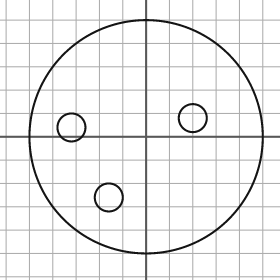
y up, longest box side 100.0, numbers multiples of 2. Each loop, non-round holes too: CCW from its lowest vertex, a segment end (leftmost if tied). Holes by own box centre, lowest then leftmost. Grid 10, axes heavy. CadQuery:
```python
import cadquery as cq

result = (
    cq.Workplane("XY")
    .moveTo(0.0, 0.0)
    .circle(50.0)
    .moveTo(-16.0, -26.0)
    .circle(6.0)
    .moveTo(-32.0, 4.0)
    .circle(6.0)
    .moveTo(20.0, 8.0)
    .circle(6.0)
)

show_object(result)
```